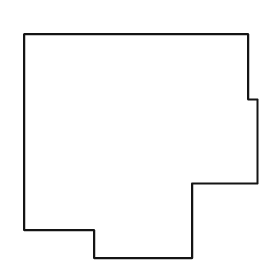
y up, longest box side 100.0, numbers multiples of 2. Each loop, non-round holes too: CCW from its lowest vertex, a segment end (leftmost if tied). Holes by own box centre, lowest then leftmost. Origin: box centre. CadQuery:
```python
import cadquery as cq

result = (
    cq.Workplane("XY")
    .moveTo(-20.0, -48.0)
    .lineTo(22.0, -48.0)
    .lineTo(22.0, -16.0)
    .lineTo(50.0, -16.0)
    .lineTo(50.0, 20.0)
    .lineTo(46.0, 20.0)
    .lineTo(46.0, 48.0)
    .lineTo(-50.0, 48.0)
    .lineTo(-50.0, -36.0)
    .lineTo(-20.0, -36.0)
    .close()
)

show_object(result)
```